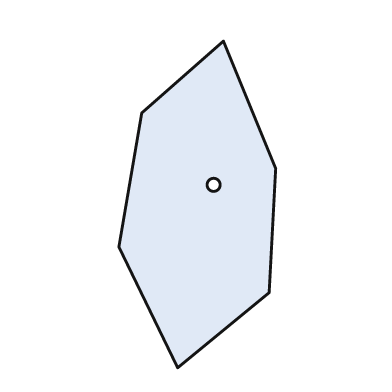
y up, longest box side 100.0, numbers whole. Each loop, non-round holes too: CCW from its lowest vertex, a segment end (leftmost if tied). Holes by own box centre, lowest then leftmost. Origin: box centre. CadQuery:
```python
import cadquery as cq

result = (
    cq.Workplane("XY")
    .moveTo(-6.0, -50.0)
    .lineTo(22.0, -27.0)
    .lineTo(24.0, 11.0)
    .lineTo(8.0, 50.0)
    .lineTo(-17.0, 28.0)
    .lineTo(-24.0, -13.0)
    .close()
    .moveTo(5.0, 6.0)
    .circle(2.0)
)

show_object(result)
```